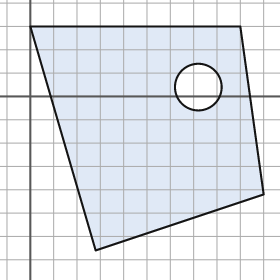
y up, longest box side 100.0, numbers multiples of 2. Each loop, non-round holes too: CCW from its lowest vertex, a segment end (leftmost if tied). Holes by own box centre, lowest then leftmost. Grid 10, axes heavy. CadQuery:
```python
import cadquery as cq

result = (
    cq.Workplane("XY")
    .moveTo(28.0, -66.0)
    .lineTo(100.0, -42.0)
    .lineTo(90.0, 30.0)
    .lineTo(0.0, 30.0)
    .close()
    .moveTo(72.0, 4.0)
    .circle(10.0)
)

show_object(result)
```